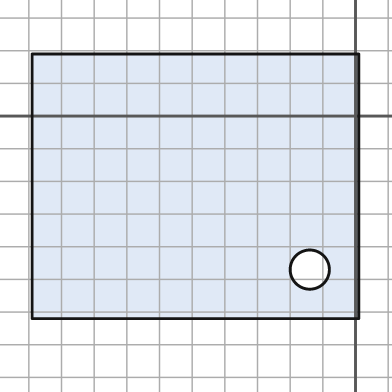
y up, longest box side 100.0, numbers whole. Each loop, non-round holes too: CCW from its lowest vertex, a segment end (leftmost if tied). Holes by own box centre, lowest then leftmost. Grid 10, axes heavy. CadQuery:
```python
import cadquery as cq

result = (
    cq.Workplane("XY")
    .moveTo(-99.0, -62.0)
    .lineTo(1.0, -62.0)
    .lineTo(1.0, 19.0)
    .lineTo(-99.0, 19.0)
    .close()
    .moveTo(-14.0, -47.0)
    .circle(6.0)
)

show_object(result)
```